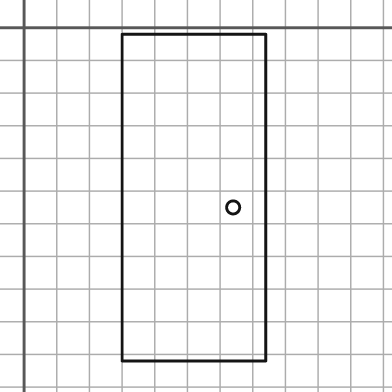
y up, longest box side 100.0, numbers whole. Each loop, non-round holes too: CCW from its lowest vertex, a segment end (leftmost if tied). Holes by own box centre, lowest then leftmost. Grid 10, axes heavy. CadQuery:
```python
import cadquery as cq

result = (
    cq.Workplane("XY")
    .moveTo(30.0, -102.0)
    .lineTo(74.0, -102.0)
    .lineTo(74.0, -2.0)
    .lineTo(30.0, -2.0)
    .close()
    .moveTo(64.0, -55.0)
    .circle(2.0)
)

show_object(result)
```